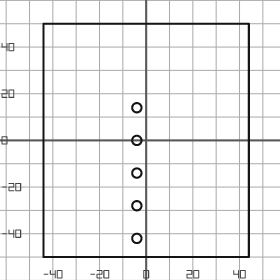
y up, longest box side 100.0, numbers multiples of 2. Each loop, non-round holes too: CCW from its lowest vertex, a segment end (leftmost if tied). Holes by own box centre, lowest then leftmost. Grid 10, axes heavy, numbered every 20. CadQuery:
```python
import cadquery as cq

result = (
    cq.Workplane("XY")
    .moveTo(-44.0, -50.0)
    .lineTo(44.0, -50.0)
    .lineTo(44.0, 50.0)
    .lineTo(-44.0, 50.0)
    .close()
    .moveTo(-4.0, -42.0)
    .circle(2.0)
    .moveTo(-4.0, -28.0)
    .circle(2.0)
    .moveTo(-4.0, -14.0)
    .circle(2.0)
    .moveTo(-4.0, 0.0)
    .circle(2.0)
    .moveTo(-4.0, 14.0)
    .circle(2.0)
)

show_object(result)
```